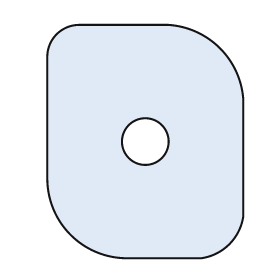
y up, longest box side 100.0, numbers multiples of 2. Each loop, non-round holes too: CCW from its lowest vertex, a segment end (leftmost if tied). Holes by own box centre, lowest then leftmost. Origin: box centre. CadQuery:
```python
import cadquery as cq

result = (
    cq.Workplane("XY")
    .moveTo(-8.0, -50.0)
    .lineTo(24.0, -50.0)
    .threePointArc((36.0, -44.0), (42.0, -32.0))
    .lineTo(42.0, 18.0)
    .threePointArc((32.0, 40.0), (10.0, 50.0))
    .lineTo(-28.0, 50.0)
    .threePointArc((-38.0, 46.0), (-42.0, 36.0))
    .lineTo(-42.0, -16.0)
    .threePointArc((-32.0, -40.0), (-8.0, -50.0))
    .close()
    .moveTo(0.0, 0.0)
    .circle(10.0)
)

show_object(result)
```